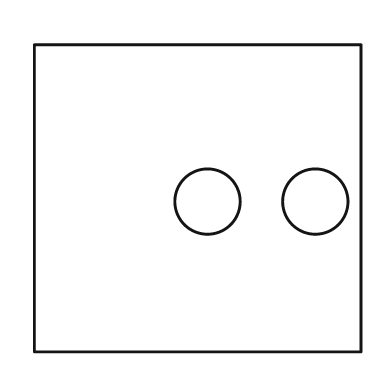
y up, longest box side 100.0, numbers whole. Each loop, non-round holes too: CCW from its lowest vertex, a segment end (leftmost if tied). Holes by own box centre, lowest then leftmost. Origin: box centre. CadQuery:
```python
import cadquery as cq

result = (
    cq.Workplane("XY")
    .moveTo(-50.0, -47.0)
    .lineTo(50.0, -47.0)
    .lineTo(50.0, 47.0)
    .lineTo(-50.0, 47.0)
    .close()
    .moveTo(3.0, -1.0)
    .circle(10.0)
    .moveTo(36.0, -1.0)
    .circle(10.0)
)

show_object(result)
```